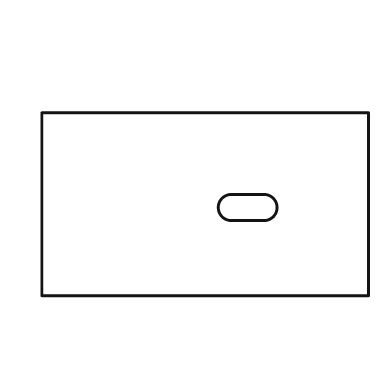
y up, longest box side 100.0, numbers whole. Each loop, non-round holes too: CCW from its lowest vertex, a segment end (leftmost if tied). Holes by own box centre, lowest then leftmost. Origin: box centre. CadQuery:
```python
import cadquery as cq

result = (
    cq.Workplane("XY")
    .moveTo(-50.0, -28.0)
    .lineTo(50.0, -28.0)
    .lineTo(50.0, 28.0)
    .lineTo(-50.0, 28.0)
    .close()
    .moveTo(8.0, -5.0)
    .lineTo(18.0, -5.0)
    .threePointArc((22.0, -1.0), (18.0, 3.0))
    .lineTo(8.0, 3.0)
    .threePointArc((4.0, -1.0), (8.0, -5.0))
    .close()
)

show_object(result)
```